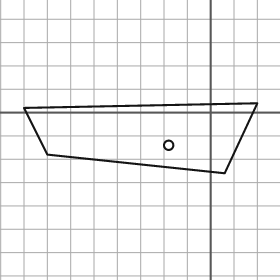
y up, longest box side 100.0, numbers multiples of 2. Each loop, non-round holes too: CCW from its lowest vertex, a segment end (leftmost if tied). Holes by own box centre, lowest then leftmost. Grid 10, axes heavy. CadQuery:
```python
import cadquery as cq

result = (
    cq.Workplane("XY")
    .moveTo(6.0, -26.0)
    .lineTo(20.0, 4.0)
    .lineTo(-80.0, 2.0)
    .lineTo(-70.0, -18.0)
    .close()
    .moveTo(-18.0, -14.0)
    .circle(2.0)
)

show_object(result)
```